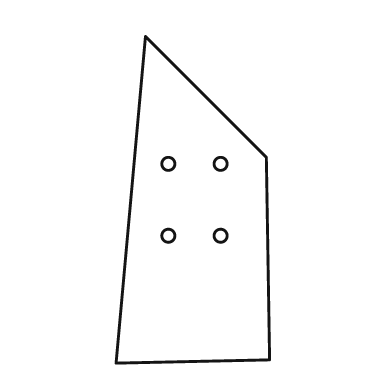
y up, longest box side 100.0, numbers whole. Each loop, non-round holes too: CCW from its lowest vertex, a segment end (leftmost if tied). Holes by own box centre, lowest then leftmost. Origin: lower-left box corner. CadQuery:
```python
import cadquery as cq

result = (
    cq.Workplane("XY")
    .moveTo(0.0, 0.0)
    .lineTo(47.0, 1.0)
    .lineTo(46.0, 63.0)
    .lineTo(9.0, 100.0)
    .close()
    .moveTo(16.0, 39.0)
    .circle(2.0)
    .moveTo(32.0, 39.0)
    .circle(2.0)
    .moveTo(16.0, 61.0)
    .circle(2.0)
    .moveTo(32.0, 61.0)
    .circle(2.0)
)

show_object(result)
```